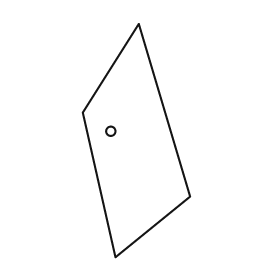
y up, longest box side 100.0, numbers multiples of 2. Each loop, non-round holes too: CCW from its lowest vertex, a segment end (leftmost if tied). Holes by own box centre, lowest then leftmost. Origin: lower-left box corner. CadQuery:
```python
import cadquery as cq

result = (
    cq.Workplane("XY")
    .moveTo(14.0, 0.0)
    .lineTo(46.0, 26.0)
    .lineTo(24.0, 100.0)
    .lineTo(0.0, 62.0)
    .close()
    .moveTo(12.0, 54.0)
    .circle(2.0)
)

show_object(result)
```